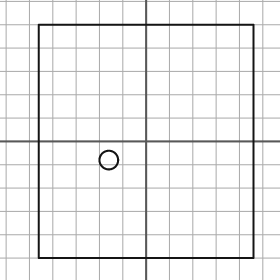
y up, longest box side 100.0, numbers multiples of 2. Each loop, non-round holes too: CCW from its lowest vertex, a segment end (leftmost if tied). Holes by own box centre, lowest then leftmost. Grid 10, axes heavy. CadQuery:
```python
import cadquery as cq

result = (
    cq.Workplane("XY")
    .moveTo(-46.0, -50.0)
    .lineTo(46.0, -50.0)
    .lineTo(46.0, 50.0)
    .lineTo(-46.0, 50.0)
    .close()
    .moveTo(-16.0, -8.0)
    .circle(4.0)
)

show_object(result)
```